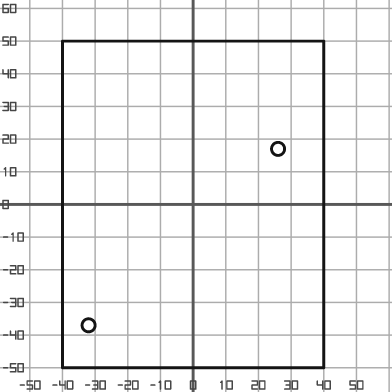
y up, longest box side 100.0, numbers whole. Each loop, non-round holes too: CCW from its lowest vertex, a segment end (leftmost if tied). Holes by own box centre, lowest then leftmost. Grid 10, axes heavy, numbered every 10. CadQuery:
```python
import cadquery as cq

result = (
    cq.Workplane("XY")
    .moveTo(-40.0, -50.0)
    .lineTo(40.0, -50.0)
    .lineTo(40.0, 50.0)
    .lineTo(-40.0, 50.0)
    .close()
    .moveTo(-32.0, -37.0)
    .circle(2.0)
    .moveTo(26.0, 17.0)
    .circle(2.0)
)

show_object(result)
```